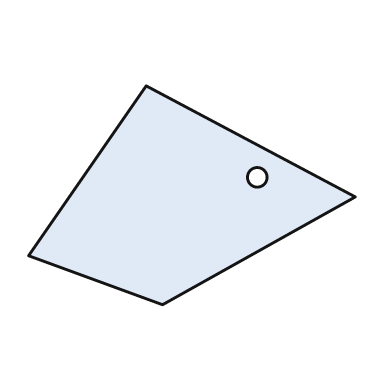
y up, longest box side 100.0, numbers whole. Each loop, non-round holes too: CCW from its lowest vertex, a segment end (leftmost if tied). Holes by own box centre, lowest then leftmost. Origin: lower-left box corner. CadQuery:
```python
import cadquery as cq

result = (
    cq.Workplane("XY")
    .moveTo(41.0, 0.0)
    .lineTo(100.0, 33.0)
    .lineTo(36.0, 67.0)
    .lineTo(0.0, 15.0)
    .close()
    .moveTo(70.0, 39.0)
    .circle(3.0)
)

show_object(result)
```